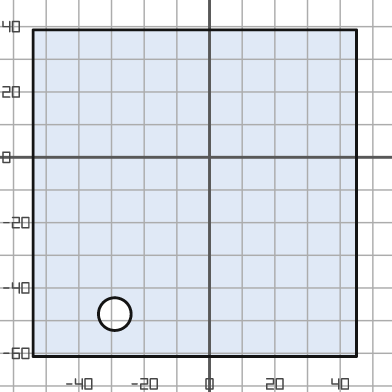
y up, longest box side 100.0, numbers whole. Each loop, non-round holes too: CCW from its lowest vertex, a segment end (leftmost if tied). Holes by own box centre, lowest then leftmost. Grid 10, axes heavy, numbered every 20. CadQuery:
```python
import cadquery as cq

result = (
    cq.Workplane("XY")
    .moveTo(-54.0, -61.0)
    .lineTo(45.0, -61.0)
    .lineTo(45.0, 39.0)
    .lineTo(-54.0, 39.0)
    .close()
    .moveTo(-29.0, -48.0)
    .circle(5.0)
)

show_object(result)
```